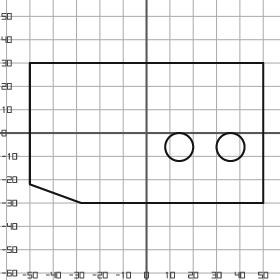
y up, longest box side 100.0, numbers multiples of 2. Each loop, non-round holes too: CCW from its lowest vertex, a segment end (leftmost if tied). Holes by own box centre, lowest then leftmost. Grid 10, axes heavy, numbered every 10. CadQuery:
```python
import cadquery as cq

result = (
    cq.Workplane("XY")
    .moveTo(-28.0, -30.0)
    .lineTo(50.0, -30.0)
    .lineTo(50.0, 30.0)
    .lineTo(-50.0, 30.0)
    .lineTo(-50.0, -22.0)
    .close()
    .moveTo(14.0, -6.0)
    .circle(6.0)
    .moveTo(36.0, -6.0)
    .circle(6.0)
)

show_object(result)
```